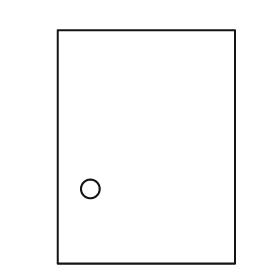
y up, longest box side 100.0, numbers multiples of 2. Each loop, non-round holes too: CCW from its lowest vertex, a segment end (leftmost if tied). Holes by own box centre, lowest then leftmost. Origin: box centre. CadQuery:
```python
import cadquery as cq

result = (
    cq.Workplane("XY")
    .moveTo(-38.0, -50.0)
    .lineTo(38.0, -50.0)
    .lineTo(38.0, 50.0)
    .lineTo(-38.0, 50.0)
    .close()
    .moveTo(-24.0, -18.0)
    .circle(4.0)
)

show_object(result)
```